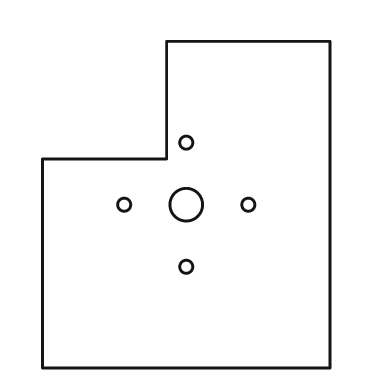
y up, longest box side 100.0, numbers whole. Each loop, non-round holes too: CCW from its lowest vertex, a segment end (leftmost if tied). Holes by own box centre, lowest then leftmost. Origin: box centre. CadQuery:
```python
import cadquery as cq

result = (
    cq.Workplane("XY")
    .moveTo(-44.0, -50.0)
    .lineTo(44.0, -50.0)
    .lineTo(44.0, 50.0)
    .lineTo(-6.0, 50.0)
    .lineTo(-6.0, 14.0)
    .lineTo(-44.0, 14.0)
    .close()
    .moveTo(0.0, -19.0)
    .circle(2.0)
    .moveTo(-19.0, 0.0)
    .circle(2.0)
    .moveTo(0.0, 0.0)
    .circle(5.0)
    .moveTo(19.0, 0.0)
    .circle(2.0)
    .moveTo(0.0, 19.0)
    .circle(2.0)
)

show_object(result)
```